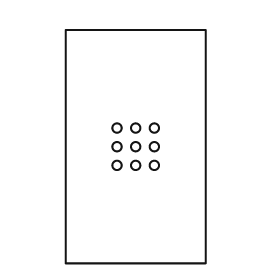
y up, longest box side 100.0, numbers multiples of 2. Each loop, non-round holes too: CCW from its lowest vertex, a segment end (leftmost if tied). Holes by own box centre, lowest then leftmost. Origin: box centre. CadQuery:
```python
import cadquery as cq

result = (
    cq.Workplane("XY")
    .moveTo(-30.0, -50.0)
    .lineTo(30.0, -50.0)
    .lineTo(30.0, 50.0)
    .lineTo(-30.0, 50.0)
    .close()
    .moveTo(-8.0, -8.0)
    .circle(2.0)
    .moveTo(0.0, -8.0)
    .circle(2.0)
    .moveTo(8.0, -8.0)
    .circle(2.0)
    .moveTo(-8.0, 0.0)
    .circle(2.0)
    .moveTo(0.0, 0.0)
    .circle(2.0)
    .moveTo(8.0, 0.0)
    .circle(2.0)
    .moveTo(-8.0, 8.0)
    .circle(2.0)
    .moveTo(0.0, 8.0)
    .circle(2.0)
    .moveTo(8.0, 8.0)
    .circle(2.0)
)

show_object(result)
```